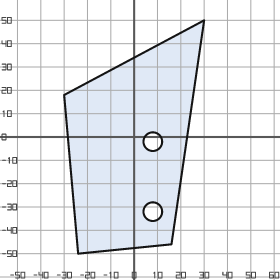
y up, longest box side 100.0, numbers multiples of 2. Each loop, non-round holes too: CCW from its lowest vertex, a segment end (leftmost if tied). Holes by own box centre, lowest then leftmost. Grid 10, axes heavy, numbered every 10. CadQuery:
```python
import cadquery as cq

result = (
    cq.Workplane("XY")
    .moveTo(-24.0, -50.0)
    .lineTo(16.0, -46.0)
    .lineTo(30.0, 50.0)
    .lineTo(-30.0, 18.0)
    .close()
    .moveTo(8.0, -32.0)
    .circle(4.0)
    .moveTo(8.0, -2.0)
    .circle(4.0)
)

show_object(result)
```